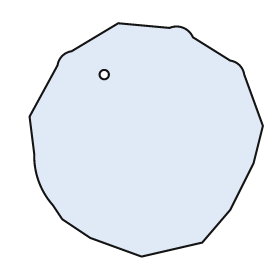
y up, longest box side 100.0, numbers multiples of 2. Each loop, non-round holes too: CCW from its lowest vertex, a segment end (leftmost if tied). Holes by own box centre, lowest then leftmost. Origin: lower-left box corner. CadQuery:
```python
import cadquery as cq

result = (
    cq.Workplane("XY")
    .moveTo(48.0, 0.0)
    .lineTo(74.0, 6.0)
    .lineTo(86.0, 20.0)
    .lineTo(96.0, 40.0)
    .lineTo(100.0, 56.0)
    .lineTo(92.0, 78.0)
    .threePointArc((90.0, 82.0), (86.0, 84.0))
    .lineTo(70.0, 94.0)
    .threePointArc((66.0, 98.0), (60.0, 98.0))
    .lineTo(38.0, 100.0)
    .lineTo(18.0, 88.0)
    .threePointArc((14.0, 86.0), (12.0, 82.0))
    .lineTo(0.0, 60.0)
    .lineTo(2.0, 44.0)
    .threePointArc((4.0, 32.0), (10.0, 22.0))
    .lineTo(14.0, 16.0)
    .lineTo(26.0, 8.0)
    .close()
    .moveTo(32.0, 78.0)
    .circle(2.0)
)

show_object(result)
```